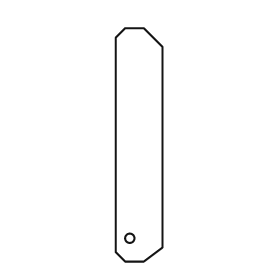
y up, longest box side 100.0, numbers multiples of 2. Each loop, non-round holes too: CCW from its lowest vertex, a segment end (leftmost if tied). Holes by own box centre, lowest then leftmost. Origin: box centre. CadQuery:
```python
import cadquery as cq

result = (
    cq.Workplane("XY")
    .moveTo(-6.0, -50.0)
    .lineTo(2.0, -50.0)
    .lineTo(10.0, -44.0)
    .lineTo(10.0, 42.0)
    .lineTo(2.0, 50.0)
    .lineTo(-6.0, 50.0)
    .lineTo(-10.0, 46.0)
    .lineTo(-10.0, -46.0)
    .close()
    .moveTo(-4.0, -40.0)
    .circle(2.0)
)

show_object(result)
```